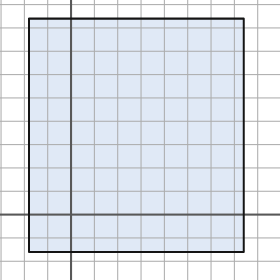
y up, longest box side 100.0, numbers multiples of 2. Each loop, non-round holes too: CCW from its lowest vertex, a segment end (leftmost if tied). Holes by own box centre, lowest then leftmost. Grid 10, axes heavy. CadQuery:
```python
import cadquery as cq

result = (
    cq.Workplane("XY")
    .moveTo(-18.0, -16.0)
    .lineTo(74.0, -16.0)
    .lineTo(74.0, 84.0)
    .lineTo(-18.0, 84.0)
    .close()
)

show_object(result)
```